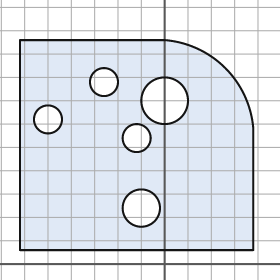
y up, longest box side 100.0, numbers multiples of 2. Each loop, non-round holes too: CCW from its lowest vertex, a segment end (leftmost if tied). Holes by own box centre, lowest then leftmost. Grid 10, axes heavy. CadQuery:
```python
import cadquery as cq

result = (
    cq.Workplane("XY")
    .moveTo(-62.0, 6.0)
    .lineTo(38.0, 6.0)
    .lineTo(38.0, 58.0)
    .threePointArc((26.0, 84.0), (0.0, 96.0))
    .lineTo(-62.0, 96.0)
    .close()
    .moveTo(-10.0, 24.0)
    .circle(8.0)
    .moveTo(-12.0, 54.0)
    .circle(6.0)
    .moveTo(-50.0, 62.0)
    .circle(6.0)
    .moveTo(0.0, 70.0)
    .circle(10.0)
    .moveTo(-26.0, 78.0)
    .circle(6.0)
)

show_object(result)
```